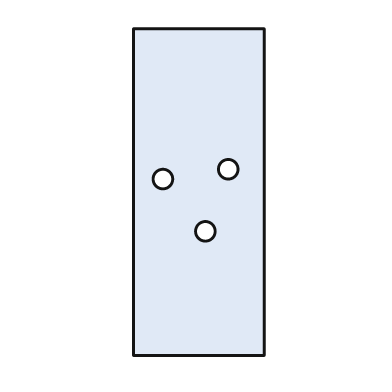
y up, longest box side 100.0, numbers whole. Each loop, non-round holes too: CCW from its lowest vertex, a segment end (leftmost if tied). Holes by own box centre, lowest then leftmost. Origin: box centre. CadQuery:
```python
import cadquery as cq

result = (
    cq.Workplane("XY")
    .moveTo(-20.0, -50.0)
    .lineTo(20.0, -50.0)
    .lineTo(20.0, 50.0)
    .lineTo(-20.0, 50.0)
    .close()
    .moveTo(2.0, -12.0)
    .circle(3.0)
    .moveTo(-11.0, 4.0)
    .circle(3.0)
    .moveTo(9.0, 7.0)
    .circle(3.0)
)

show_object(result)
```